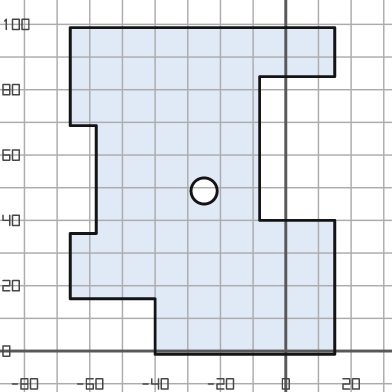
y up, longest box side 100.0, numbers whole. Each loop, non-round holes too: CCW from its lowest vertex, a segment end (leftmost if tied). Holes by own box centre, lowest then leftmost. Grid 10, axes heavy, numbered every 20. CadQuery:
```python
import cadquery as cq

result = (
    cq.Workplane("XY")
    .moveTo(-40.0, -1.0)
    .lineTo(15.0, -1.0)
    .lineTo(15.0, 40.0)
    .lineTo(-8.0, 40.0)
    .lineTo(-8.0, 84.0)
    .lineTo(15.0, 84.0)
    .lineTo(15.0, 99.0)
    .lineTo(-66.0, 99.0)
    .lineTo(-66.0, 69.0)
    .lineTo(-58.0, 69.0)
    .lineTo(-58.0, 36.0)
    .lineTo(-66.0, 36.0)
    .lineTo(-66.0, 16.0)
    .lineTo(-40.0, 16.0)
    .close()
    .moveTo(-25.0, 49.0)
    .circle(4.0)
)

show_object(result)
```